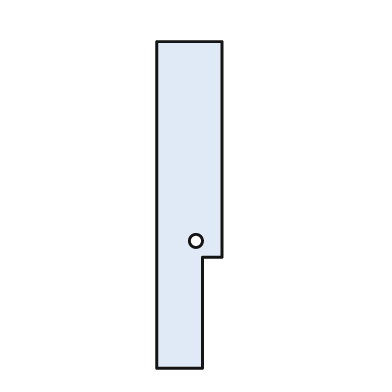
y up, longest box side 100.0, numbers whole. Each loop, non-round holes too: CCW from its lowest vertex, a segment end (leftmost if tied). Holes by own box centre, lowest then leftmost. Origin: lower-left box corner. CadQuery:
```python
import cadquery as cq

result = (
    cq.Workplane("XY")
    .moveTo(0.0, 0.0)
    .lineTo(14.0, 0.0)
    .lineTo(14.0, 34.0)
    .lineTo(20.0, 34.0)
    .lineTo(20.0, 100.0)
    .lineTo(0.0, 100.0)
    .close()
    .moveTo(12.0, 39.0)
    .circle(2.0)
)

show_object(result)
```